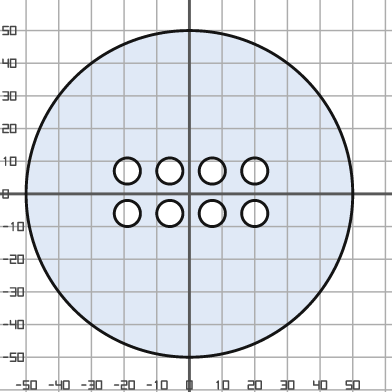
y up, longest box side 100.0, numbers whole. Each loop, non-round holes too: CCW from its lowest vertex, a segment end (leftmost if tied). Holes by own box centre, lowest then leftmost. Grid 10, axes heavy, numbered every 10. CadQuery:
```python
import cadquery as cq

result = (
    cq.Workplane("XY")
    .moveTo(0.0, 0.0)
    .circle(50.0)
    .moveTo(-19.0, -6.0)
    .circle(4.0)
    .moveTo(-6.0, -6.0)
    .circle(4.0)
    .moveTo(7.0, -6.0)
    .circle(4.0)
    .moveTo(20.0, -6.0)
    .circle(4.0)
    .moveTo(-19.0, 7.0)
    .circle(4.0)
    .moveTo(-6.0, 7.0)
    .circle(4.0)
    .moveTo(7.0, 7.0)
    .circle(4.0)
    .moveTo(20.0, 7.0)
    .circle(4.0)
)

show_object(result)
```